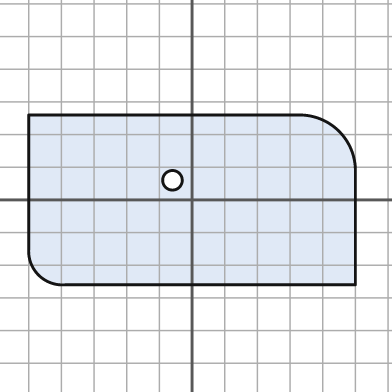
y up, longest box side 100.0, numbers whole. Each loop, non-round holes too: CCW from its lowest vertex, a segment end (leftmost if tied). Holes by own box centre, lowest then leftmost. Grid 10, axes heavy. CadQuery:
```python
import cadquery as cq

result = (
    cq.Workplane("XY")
    .moveTo(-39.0, -26.0)
    .lineTo(50.0, -26.0)
    .lineTo(50.0, 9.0)
    .threePointArc((45.0, 21.0), (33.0, 26.0))
    .lineTo(-50.0, 26.0)
    .lineTo(-50.0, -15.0)
    .threePointArc((-47.0, -23.0), (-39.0, -26.0))
    .close()
    .moveTo(-6.0, 6.0)
    .circle(3.0)
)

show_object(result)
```